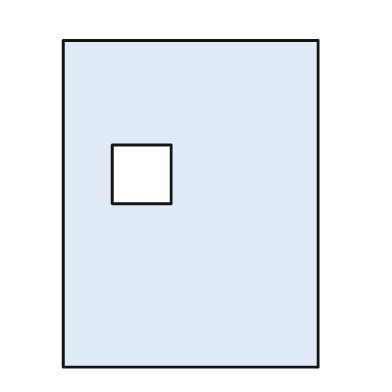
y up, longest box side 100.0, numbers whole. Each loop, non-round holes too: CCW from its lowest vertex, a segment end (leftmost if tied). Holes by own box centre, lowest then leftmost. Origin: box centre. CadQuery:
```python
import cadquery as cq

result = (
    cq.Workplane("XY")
    .moveTo(-39.0, -50.0)
    .lineTo(39.0, -50.0)
    .lineTo(39.0, 50.0)
    .lineTo(-39.0, 50.0)
    .close()
    .moveTo(-24.0, 0.0)
    .lineTo(-6.0, 0.0)
    .lineTo(-6.0, 18.0)
    .lineTo(-24.0, 18.0)
    .close()
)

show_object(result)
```